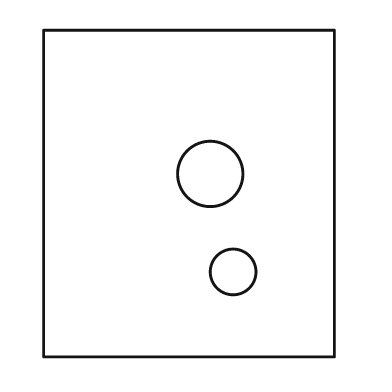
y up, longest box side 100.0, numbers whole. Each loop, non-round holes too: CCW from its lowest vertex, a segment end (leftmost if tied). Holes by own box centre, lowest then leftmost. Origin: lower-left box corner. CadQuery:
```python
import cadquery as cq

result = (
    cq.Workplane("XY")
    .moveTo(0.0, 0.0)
    .lineTo(89.0, 0.0)
    .lineTo(89.0, 100.0)
    .lineTo(0.0, 100.0)
    .close()
    .moveTo(58.0, 26.0)
    .circle(7.0)
    .moveTo(51.0, 56.0)
    .circle(10.0)
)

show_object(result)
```